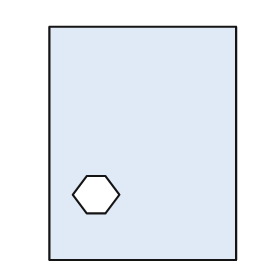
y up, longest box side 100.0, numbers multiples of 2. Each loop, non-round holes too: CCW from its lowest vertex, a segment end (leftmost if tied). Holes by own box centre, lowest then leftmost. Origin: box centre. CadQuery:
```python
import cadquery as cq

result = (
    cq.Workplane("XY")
    .moveTo(-40.0, -50.0)
    .lineTo(40.0, -50.0)
    .lineTo(40.0, 50.0)
    .lineTo(-40.0, 50.0)
    .close()
    .moveTo(-24.0, -30.0)
    .lineTo(-16.0, -30.0)
    .lineTo(-10.0, -22.0)
    .lineTo(-16.0, -14.0)
    .lineTo(-24.0, -14.0)
    .lineTo(-30.0, -22.0)
    .close()
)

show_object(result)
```